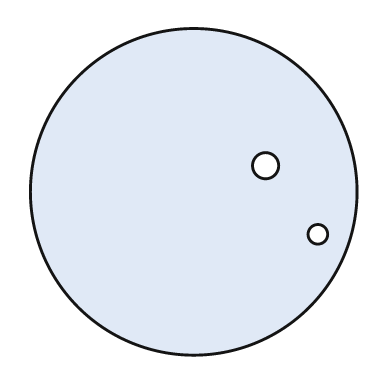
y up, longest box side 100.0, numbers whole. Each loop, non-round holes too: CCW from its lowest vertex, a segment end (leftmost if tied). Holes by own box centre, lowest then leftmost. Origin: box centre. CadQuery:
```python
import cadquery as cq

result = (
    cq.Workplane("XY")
    .moveTo(0.0, 0.0)
    .circle(50.0)
    .moveTo(38.0, -13.0)
    .circle(3.0)
    .moveTo(22.0, 8.0)
    .circle(4.0)
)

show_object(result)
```